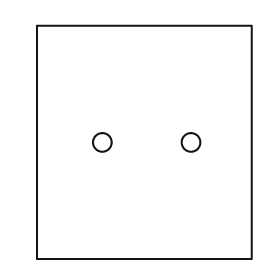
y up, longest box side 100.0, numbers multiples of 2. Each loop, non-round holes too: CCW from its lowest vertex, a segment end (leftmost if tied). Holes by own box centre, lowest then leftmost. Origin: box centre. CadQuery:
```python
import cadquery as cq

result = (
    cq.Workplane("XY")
    .moveTo(-46.0, -50.0)
    .lineTo(46.0, -50.0)
    .lineTo(46.0, 50.0)
    .lineTo(-46.0, 50.0)
    .close()
    .moveTo(-18.0, 0.0)
    .circle(4.0)
    .moveTo(20.0, 0.0)
    .circle(4.0)
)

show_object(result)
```